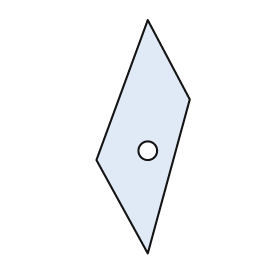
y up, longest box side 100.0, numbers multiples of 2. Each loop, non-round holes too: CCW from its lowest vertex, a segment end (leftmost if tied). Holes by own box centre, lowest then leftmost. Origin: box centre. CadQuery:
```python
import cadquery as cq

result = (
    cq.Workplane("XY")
    .moveTo(2.0, -50.0)
    .lineTo(20.0, 16.0)
    .lineTo(2.0, 50.0)
    .lineTo(-20.0, -10.0)
    .close()
    .moveTo(2.0, -6.0)
    .circle(4.0)
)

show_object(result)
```